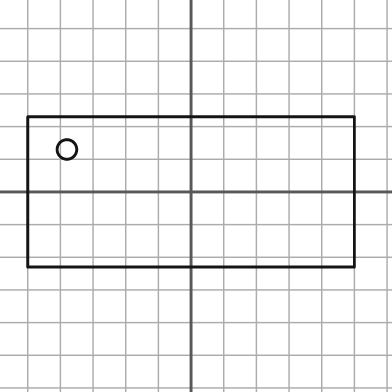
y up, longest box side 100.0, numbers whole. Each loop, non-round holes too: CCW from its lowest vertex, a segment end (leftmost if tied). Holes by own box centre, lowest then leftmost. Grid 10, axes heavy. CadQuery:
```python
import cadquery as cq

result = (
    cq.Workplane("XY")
    .moveTo(-50.0, -23.0)
    .lineTo(50.0, -23.0)
    .lineTo(50.0, 23.0)
    .lineTo(-50.0, 23.0)
    .close()
    .moveTo(-38.0, 13.0)
    .circle(3.0)
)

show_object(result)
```